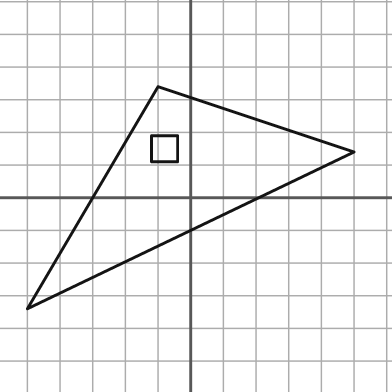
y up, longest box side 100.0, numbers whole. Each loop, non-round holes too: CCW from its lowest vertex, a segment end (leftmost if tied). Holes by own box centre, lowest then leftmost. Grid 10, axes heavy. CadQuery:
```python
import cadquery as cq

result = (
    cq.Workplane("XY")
    .moveTo(-50.0, -34.0)
    .lineTo(50.0, 14.0)
    .lineTo(-10.0, 34.0)
    .close()
    .moveTo(-12.0, 11.0)
    .lineTo(-4.0, 11.0)
    .lineTo(-4.0, 19.0)
    .lineTo(-12.0, 19.0)
    .close()
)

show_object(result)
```